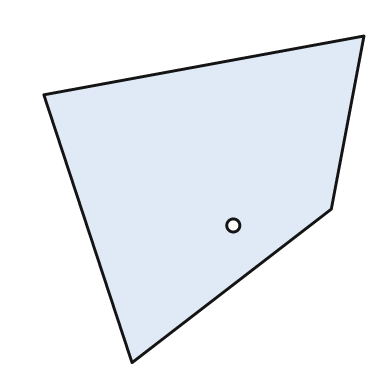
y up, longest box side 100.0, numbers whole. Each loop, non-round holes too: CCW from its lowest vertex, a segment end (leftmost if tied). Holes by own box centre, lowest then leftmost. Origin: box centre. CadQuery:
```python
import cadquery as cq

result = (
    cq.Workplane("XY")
    .moveTo(-22.0, -50.0)
    .lineTo(39.0, -3.0)
    .lineTo(49.0, 50.0)
    .lineTo(-49.0, 32.0)
    .close()
    .moveTo(9.0, -8.0)
    .circle(2.0)
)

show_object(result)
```